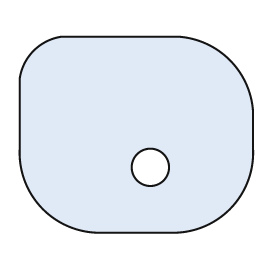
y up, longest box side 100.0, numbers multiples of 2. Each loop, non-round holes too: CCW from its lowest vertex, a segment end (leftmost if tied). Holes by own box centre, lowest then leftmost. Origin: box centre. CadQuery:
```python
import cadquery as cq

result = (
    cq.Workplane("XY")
    .moveTo(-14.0, -42.0)
    .lineTo(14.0, -42.0)
    .threePointArc((40.0, -32.0), (50.0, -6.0))
    .lineTo(50.0, 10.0)
    .threePointArc((40.0, 32.0), (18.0, 42.0))
    .lineTo(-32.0, 42.0)
    .threePointArc((-44.0, 36.0), (-50.0, 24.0))
    .lineTo(-50.0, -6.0)
    .threePointArc((-40.0, -32.0), (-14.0, -42.0))
    .close()
    .moveTo(6.0, -14.0)
    .circle(8.0)
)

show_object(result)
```